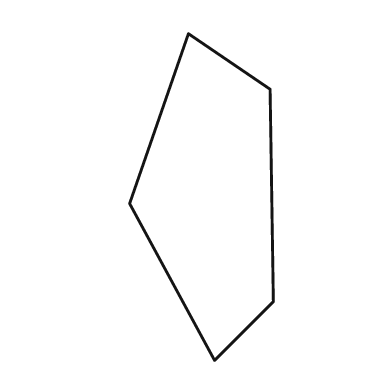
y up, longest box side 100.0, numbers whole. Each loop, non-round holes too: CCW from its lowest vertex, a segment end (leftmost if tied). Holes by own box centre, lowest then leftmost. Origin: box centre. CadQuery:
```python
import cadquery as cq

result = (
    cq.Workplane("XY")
    .moveTo(4.0, -50.0)
    .lineTo(22.0, -32.0)
    .lineTo(21.0, 33.0)
    .lineTo(-4.0, 50.0)
    .lineTo(-22.0, -2.0)
    .close()
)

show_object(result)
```